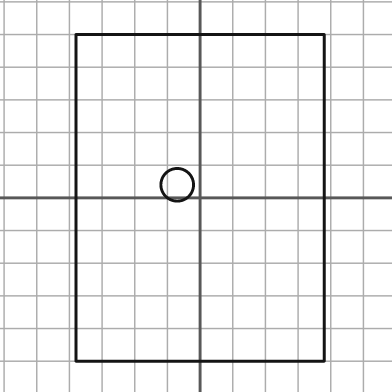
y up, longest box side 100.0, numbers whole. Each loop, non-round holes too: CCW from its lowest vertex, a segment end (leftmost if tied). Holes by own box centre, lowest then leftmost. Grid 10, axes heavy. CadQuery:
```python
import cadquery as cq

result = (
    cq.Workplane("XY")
    .moveTo(-38.0, -50.0)
    .lineTo(38.0, -50.0)
    .lineTo(38.0, 50.0)
    .lineTo(-38.0, 50.0)
    .close()
    .moveTo(-7.0, 4.0)
    .circle(5.0)
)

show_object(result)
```